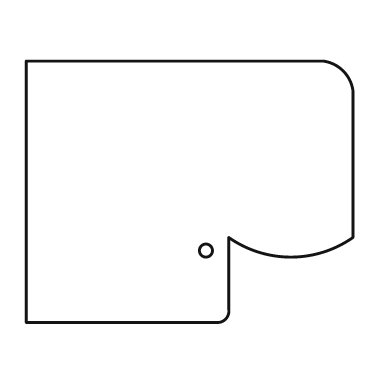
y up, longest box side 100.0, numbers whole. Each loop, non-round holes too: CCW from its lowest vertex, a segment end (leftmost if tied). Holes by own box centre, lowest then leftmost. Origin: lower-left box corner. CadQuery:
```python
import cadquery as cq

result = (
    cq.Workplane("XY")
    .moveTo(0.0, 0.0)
    .lineTo(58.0, 0.0)
    .threePointArc((61.0, 1.0), (62.0, 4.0))
    .lineTo(62.0, 26.0)
    .threePointArc((81.0, 20.0), (100.0, 26.0))
    .lineTo(100.0, 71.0)
    .threePointArc((97.0, 77.0), (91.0, 80.0))
    .lineTo(0.0, 80.0)
    .close()
    .moveTo(55.0, 22.0)
    .circle(2.0)
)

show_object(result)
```